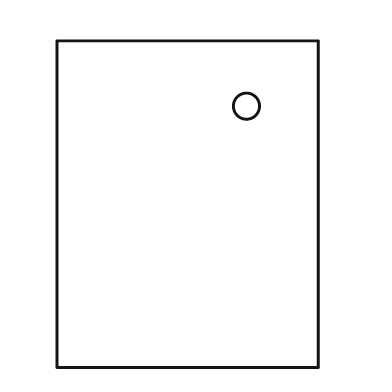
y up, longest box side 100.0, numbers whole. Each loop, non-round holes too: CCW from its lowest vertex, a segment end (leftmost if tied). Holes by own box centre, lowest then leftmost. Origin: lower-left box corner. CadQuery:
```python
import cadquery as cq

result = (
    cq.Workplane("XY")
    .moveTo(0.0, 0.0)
    .lineTo(80.0, 0.0)
    .lineTo(80.0, 100.0)
    .lineTo(0.0, 100.0)
    .close()
    .moveTo(58.0, 80.0)
    .circle(4.0)
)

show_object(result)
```